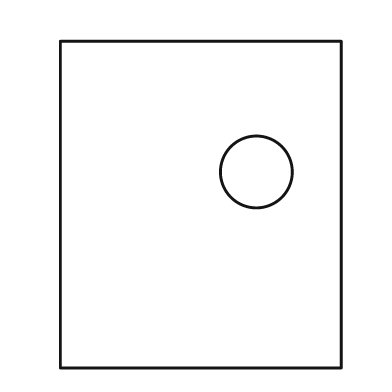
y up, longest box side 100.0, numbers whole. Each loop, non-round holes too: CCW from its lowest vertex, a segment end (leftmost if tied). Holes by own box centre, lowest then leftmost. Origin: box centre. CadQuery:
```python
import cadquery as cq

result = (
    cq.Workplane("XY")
    .moveTo(-43.0, -50.0)
    .lineTo(43.0, -50.0)
    .lineTo(43.0, 50.0)
    .lineTo(-43.0, 50.0)
    .close()
    .moveTo(17.0, 10.0)
    .circle(11.0)
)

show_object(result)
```